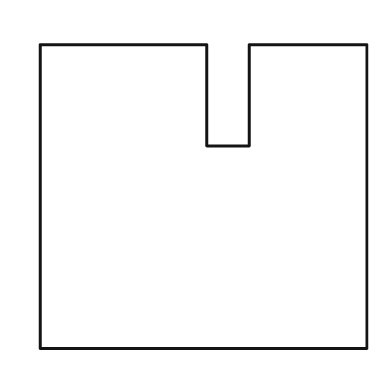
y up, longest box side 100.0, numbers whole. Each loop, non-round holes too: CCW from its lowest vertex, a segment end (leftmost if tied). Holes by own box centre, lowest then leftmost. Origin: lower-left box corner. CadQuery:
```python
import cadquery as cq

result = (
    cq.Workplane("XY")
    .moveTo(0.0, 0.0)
    .lineTo(100.0, 0.0)
    .lineTo(100.0, 93.0)
    .lineTo(64.0, 93.0)
    .lineTo(64.0, 62.0)
    .lineTo(51.0, 62.0)
    .lineTo(51.0, 93.0)
    .lineTo(0.0, 93.0)
    .close()
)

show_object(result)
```